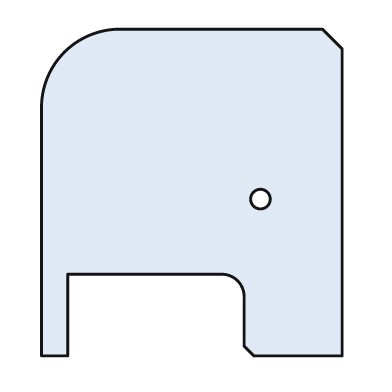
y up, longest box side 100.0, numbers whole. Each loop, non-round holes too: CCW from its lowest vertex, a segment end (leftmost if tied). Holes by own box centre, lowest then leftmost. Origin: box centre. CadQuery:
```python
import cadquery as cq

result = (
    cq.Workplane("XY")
    .moveTo(-46.0, -50.0)
    .lineTo(-38.0, -50.0)
    .lineTo(-38.0, -25.0)
    .lineTo(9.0, -25.0)
    .threePointArc((14.0, -27.0), (16.0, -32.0))
    .lineTo(16.0, -47.0)
    .lineTo(19.0, -50.0)
    .lineTo(46.0, -50.0)
    .lineTo(46.0, 44.0)
    .lineTo(40.0, 50.0)
    .lineTo(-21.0, 50.0)
    .threePointArc((-39.0, 43.0), (-46.0, 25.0))
    .close()
    .moveTo(21.0, -2.0)
    .circle(3.0)
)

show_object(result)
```